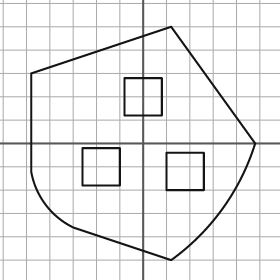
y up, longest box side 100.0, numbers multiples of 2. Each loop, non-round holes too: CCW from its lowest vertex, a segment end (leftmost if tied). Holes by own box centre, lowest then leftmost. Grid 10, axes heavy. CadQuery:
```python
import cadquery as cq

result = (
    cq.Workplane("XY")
    .moveTo(12.0, -50.0)
    .threePointArc((34.0, -28.0), (48.0, 0.0))
    .lineTo(12.0, 50.0)
    .lineTo(-48.0, 30.0)
    .lineTo(-48.0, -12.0)
    .threePointArc((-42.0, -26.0), (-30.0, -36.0))
    .close()
    .moveTo(10.0, -20.0)
    .lineTo(26.0, -20.0)
    .lineTo(26.0, -4.0)
    .lineTo(10.0, -4.0)
    .close()
    .moveTo(-26.0, -18.0)
    .lineTo(-10.0, -18.0)
    .lineTo(-10.0, -2.0)
    .lineTo(-26.0, -2.0)
    .close()
    .moveTo(-8.0, 12.0)
    .lineTo(8.0, 12.0)
    .lineTo(8.0, 28.0)
    .lineTo(-8.0, 28.0)
    .close()
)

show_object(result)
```